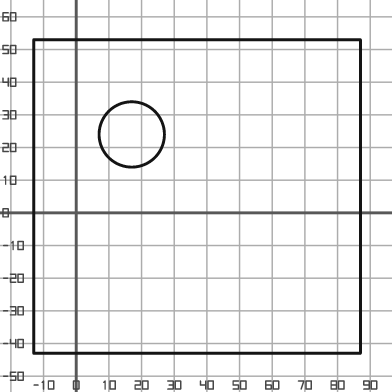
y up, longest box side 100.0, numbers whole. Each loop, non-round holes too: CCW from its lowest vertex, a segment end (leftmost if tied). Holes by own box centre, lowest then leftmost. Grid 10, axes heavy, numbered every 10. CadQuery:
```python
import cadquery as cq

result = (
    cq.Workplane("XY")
    .moveTo(-13.0, -43.0)
    .lineTo(87.0, -43.0)
    .lineTo(87.0, 53.0)
    .lineTo(-13.0, 53.0)
    .close()
    .moveTo(17.0, 24.0)
    .circle(10.0)
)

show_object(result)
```